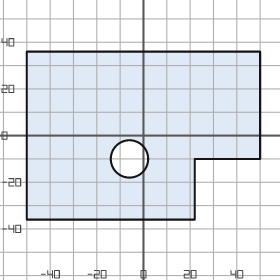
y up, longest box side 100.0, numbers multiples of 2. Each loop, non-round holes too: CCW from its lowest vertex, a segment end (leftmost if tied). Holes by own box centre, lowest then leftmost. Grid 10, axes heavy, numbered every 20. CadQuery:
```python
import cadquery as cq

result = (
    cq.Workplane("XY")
    .moveTo(-50.0, -36.0)
    .lineTo(22.0, -36.0)
    .lineTo(22.0, -10.0)
    .lineTo(50.0, -10.0)
    .lineTo(50.0, 36.0)
    .lineTo(-50.0, 36.0)
    .close()
    .moveTo(-6.0, -10.0)
    .circle(8.0)
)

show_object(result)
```